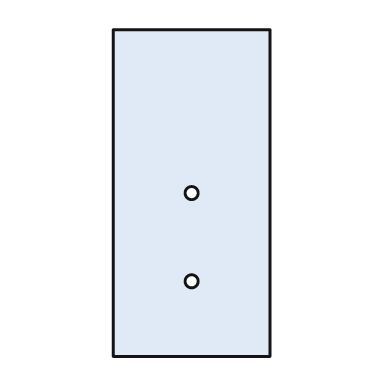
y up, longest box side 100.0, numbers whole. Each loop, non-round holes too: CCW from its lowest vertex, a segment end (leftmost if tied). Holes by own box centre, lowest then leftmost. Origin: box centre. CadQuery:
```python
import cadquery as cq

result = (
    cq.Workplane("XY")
    .moveTo(-24.0, -50.0)
    .lineTo(24.0, -50.0)
    .lineTo(24.0, 50.0)
    .lineTo(-24.0, 50.0)
    .close()
    .moveTo(0.0, -27.0)
    .circle(2.0)
    .moveTo(0.0, 0.0)
    .circle(2.0)
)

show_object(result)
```